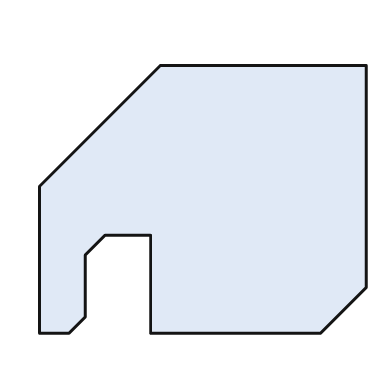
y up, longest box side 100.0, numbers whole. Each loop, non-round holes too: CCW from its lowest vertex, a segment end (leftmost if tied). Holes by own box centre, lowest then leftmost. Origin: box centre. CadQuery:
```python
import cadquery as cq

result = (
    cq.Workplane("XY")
    .moveTo(-50.0, -41.0)
    .lineTo(-41.0, -41.0)
    .lineTo(-36.0, -36.0)
    .lineTo(-36.0, -17.0)
    .lineTo(-30.0, -11.0)
    .lineTo(-16.0, -11.0)
    .lineTo(-16.0, -41.0)
    .lineTo(36.0, -41.0)
    .lineTo(50.0, -27.0)
    .lineTo(50.0, 41.0)
    .lineTo(-13.0, 41.0)
    .lineTo(-50.0, 4.0)
    .close()
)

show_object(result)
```